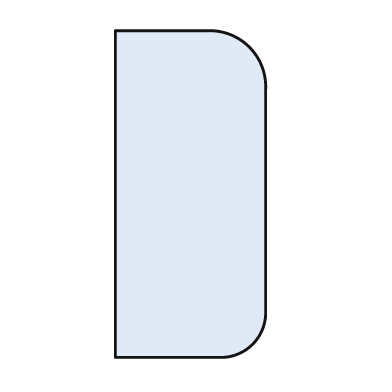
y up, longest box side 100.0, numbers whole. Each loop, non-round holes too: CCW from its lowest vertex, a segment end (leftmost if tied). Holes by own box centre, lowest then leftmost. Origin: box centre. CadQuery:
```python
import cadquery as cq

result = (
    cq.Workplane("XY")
    .moveTo(-23.0, -50.0)
    .lineTo(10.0, -50.0)
    .threePointArc((19.0, -46.0), (23.0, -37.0))
    .lineTo(23.0, 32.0)
    .threePointArc((18.0, 45.0), (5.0, 50.0))
    .lineTo(-23.0, 50.0)
    .close()
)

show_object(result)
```